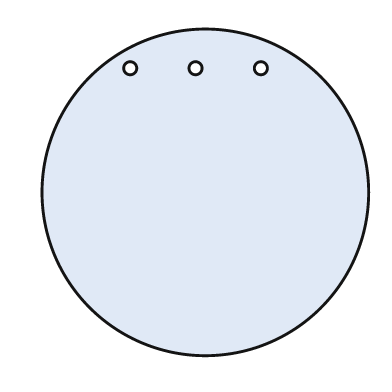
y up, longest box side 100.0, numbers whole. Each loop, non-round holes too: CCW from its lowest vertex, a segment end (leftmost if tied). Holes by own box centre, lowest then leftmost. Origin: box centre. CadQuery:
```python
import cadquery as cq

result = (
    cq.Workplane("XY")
    .moveTo(0.0, 0.0)
    .circle(50.0)
    .moveTo(-23.0, 38.0)
    .circle(2.0)
    .moveTo(-3.0, 38.0)
    .circle(2.0)
    .moveTo(17.0, 38.0)
    .circle(2.0)
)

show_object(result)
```